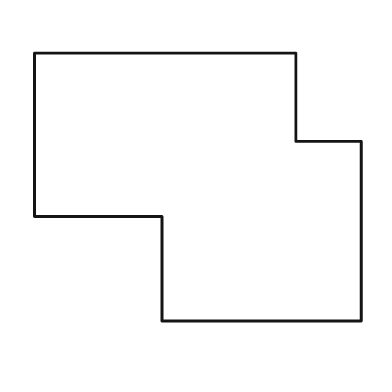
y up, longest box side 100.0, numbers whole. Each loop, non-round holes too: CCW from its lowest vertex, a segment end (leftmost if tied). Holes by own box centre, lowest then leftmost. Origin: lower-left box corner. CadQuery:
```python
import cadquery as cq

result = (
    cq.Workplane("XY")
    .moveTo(39.0, 0.0)
    .lineTo(100.0, 0.0)
    .lineTo(100.0, 55.0)
    .lineTo(80.0, 55.0)
    .lineTo(80.0, 82.0)
    .lineTo(0.0, 82.0)
    .lineTo(0.0, 32.0)
    .lineTo(39.0, 32.0)
    .close()
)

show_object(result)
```